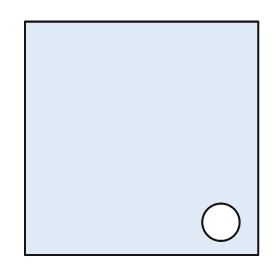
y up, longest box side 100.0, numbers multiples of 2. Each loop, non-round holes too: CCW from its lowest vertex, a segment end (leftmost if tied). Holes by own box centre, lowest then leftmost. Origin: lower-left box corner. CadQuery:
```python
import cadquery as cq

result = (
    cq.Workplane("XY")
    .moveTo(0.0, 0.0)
    .lineTo(100.0, 0.0)
    .lineTo(100.0, 100.0)
    .lineTo(0.0, 100.0)
    .close()
    .moveTo(84.0, 14.0)
    .circle(8.0)
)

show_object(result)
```